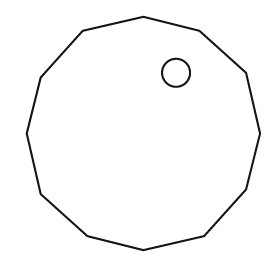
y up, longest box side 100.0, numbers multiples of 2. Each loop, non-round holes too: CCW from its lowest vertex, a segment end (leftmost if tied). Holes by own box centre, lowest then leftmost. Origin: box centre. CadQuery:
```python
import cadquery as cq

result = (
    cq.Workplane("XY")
    .moveTo(0.0, -50.0)
    .lineTo(26.0, -44.0)
    .lineTo(44.0, -24.0)
    .lineTo(50.0, 0.0)
    .lineTo(44.0, 26.0)
    .lineTo(24.0, 44.0)
    .lineTo(0.0, 50.0)
    .lineTo(-26.0, 44.0)
    .lineTo(-44.0, 24.0)
    .lineTo(-50.0, 0.0)
    .lineTo(-44.0, -26.0)
    .lineTo(-24.0, -44.0)
    .close()
    .moveTo(14.0, 26.0)
    .circle(6.0)
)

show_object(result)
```